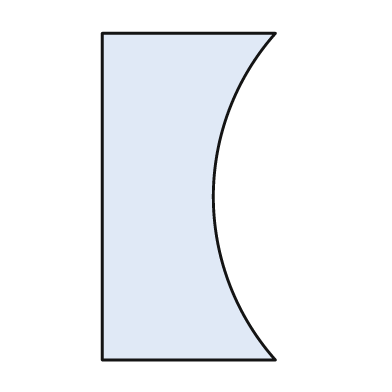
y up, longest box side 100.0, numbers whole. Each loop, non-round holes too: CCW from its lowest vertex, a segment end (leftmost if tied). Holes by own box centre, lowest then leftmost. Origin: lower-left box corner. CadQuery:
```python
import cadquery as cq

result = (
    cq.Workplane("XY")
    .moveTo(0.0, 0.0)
    .lineTo(53.0, 0.0)
    .threePointArc((34.0, 50.0), (53.0, 100.0))
    .lineTo(0.0, 100.0)
    .close()
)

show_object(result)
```